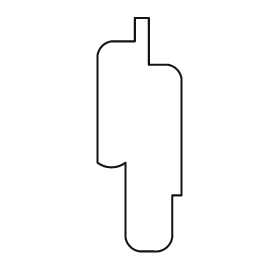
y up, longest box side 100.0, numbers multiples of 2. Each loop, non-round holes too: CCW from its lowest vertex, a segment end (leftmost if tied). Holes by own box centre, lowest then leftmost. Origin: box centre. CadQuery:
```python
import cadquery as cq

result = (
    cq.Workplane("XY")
    .moveTo(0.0, -50.0)
    .lineTo(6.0, -50.0)
    .threePointArc((12.0, -48.0), (14.0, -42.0))
    .lineTo(14.0, -26.0)
    .lineTo(18.0, -26.0)
    .lineTo(18.0, 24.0)
    .threePointArc((16.0, 28.0), (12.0, 30.0))
    .lineTo(4.0, 30.0)
    .lineTo(4.0, 50.0)
    .lineTo(-2.0, 50.0)
    .lineTo(-2.0, 40.0)
    .lineTo(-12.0, 40.0)
    .threePointArc((-16.0, 38.0), (-18.0, 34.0))
    .lineTo(-18.0, -12.0)
    .threePointArc((-12.0, -14.0), (-6.0, -12.0))
    .lineTo(-6.0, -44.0)
    .threePointArc((-4.0, -48.0), (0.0, -50.0))
    .close()
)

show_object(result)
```